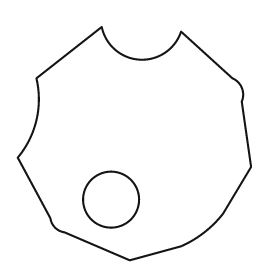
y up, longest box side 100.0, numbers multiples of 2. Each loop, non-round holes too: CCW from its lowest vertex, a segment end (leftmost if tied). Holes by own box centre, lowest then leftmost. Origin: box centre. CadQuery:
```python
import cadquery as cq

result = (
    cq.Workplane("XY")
    .moveTo(-2.0, -50.0)
    .lineTo(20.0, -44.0)
    .threePointArc((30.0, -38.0), (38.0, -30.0))
    .lineTo(50.0, -10.0)
    .lineTo(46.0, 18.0)
    .threePointArc((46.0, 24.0), (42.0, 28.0))
    .lineTo(20.0, 48.0)
    .threePointArc((2.0, 36.0), (-14.0, 50.0))
    .lineTo(-42.0, 28.0)
    .threePointArc((-42.0, 10.0), (-50.0, -6.0))
    .lineTo(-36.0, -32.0)
    .threePointArc((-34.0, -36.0), (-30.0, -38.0))
    .close()
    .moveTo(-10.0, -24.0)
    .circle(12.0)
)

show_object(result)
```